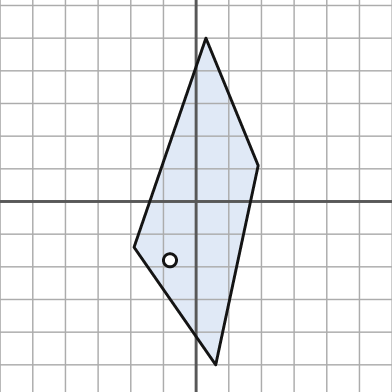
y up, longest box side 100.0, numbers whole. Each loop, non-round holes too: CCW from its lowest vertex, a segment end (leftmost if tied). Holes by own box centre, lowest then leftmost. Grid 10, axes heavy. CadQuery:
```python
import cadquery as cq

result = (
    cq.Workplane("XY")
    .moveTo(6.0, -50.0)
    .lineTo(19.0, 11.0)
    .lineTo(3.0, 50.0)
    .lineTo(-19.0, -14.0)
    .close()
    .moveTo(-8.0, -18.0)
    .circle(2.0)
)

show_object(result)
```